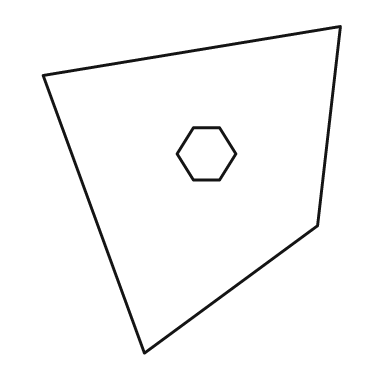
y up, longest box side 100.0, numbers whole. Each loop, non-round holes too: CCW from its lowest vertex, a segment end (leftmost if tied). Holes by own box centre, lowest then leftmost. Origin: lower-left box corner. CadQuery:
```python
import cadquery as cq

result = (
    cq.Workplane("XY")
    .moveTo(31.0, 0.0)
    .lineTo(84.0, 39.0)
    .lineTo(91.0, 100.0)
    .lineTo(0.0, 85.0)
    .close()
    .moveTo(46.0, 53.0)
    .lineTo(54.0, 53.0)
    .lineTo(59.0, 61.0)
    .lineTo(54.0, 69.0)
    .lineTo(46.0, 69.0)
    .lineTo(41.0, 61.0)
    .close()
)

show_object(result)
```